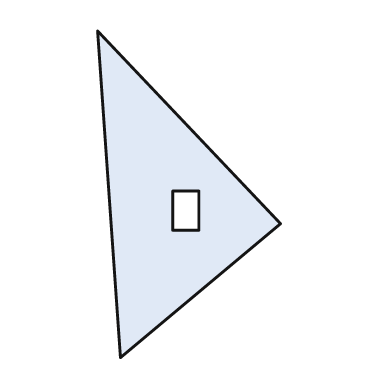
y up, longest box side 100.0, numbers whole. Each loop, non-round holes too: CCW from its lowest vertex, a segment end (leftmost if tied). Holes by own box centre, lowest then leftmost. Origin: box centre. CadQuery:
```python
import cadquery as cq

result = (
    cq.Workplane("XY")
    .moveTo(-21.0, -50.0)
    .lineTo(28.0, -9.0)
    .lineTo(-28.0, 50.0)
    .close()
    .moveTo(-5.0, -11.0)
    .lineTo(3.0, -11.0)
    .lineTo(3.0, 1.0)
    .lineTo(-5.0, 1.0)
    .close()
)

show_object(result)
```